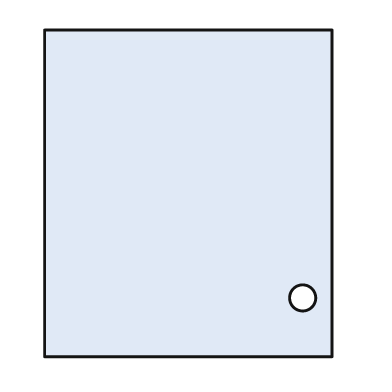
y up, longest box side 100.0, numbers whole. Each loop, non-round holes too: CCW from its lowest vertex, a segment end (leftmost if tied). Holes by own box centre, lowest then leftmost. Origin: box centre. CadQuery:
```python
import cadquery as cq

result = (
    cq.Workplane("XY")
    .moveTo(-44.0, -50.0)
    .lineTo(44.0, -50.0)
    .lineTo(44.0, 50.0)
    .lineTo(-44.0, 50.0)
    .close()
    .moveTo(35.0, -32.0)
    .circle(4.0)
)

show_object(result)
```